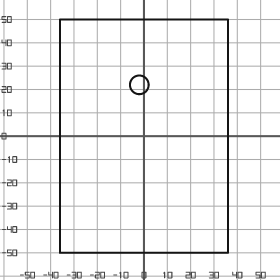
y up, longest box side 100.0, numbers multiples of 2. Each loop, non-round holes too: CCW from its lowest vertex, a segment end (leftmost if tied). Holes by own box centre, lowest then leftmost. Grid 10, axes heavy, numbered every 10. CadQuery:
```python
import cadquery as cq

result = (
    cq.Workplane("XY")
    .moveTo(-36.0, -50.0)
    .lineTo(36.0, -50.0)
    .lineTo(36.0, 50.0)
    .lineTo(-36.0, 50.0)
    .close()
    .moveTo(-2.0, 22.0)
    .circle(4.0)
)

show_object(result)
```